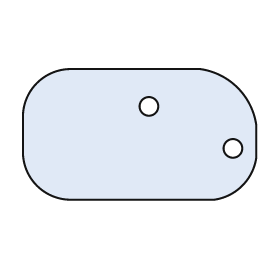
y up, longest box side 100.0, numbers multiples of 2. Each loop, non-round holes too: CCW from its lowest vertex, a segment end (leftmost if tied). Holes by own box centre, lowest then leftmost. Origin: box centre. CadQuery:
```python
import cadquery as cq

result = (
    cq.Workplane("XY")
    .moveTo(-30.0, -28.0)
    .lineTo(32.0, -28.0)
    .threePointArc((44.0, -22.0), (50.0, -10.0))
    .lineTo(50.0, 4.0)
    .threePointArc((42.0, 20.0), (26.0, 28.0))
    .lineTo(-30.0, 28.0)
    .threePointArc((-44.0, 22.0), (-50.0, 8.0))
    .lineTo(-50.0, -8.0)
    .threePointArc((-44.0, -22.0), (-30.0, -28.0))
    .close()
    .moveTo(40.0, -6.0)
    .circle(4.0)
    .moveTo(4.0, 12.0)
    .circle(4.0)
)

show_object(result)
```